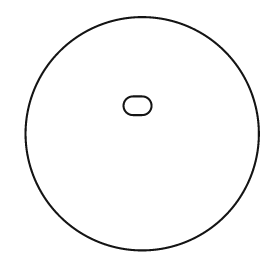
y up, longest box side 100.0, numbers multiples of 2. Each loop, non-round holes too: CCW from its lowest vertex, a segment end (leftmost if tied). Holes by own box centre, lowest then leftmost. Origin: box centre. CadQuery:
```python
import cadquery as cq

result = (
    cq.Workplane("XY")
    .moveTo(0.0, 0.0)
    .circle(50.0)
    .moveTo(-4.0, 8.0)
    .lineTo(0.0, 8.0)
    .threePointArc((4.0, 12.0), (0.0, 16.0))
    .lineTo(-4.0, 16.0)
    .threePointArc((-8.0, 12.0), (-4.0, 8.0))
    .close()
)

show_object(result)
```